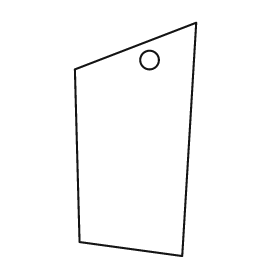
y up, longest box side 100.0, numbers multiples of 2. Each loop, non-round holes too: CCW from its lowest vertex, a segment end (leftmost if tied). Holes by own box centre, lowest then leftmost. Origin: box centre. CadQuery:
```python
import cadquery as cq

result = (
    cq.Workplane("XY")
    .moveTo(20.0, -50.0)
    .lineTo(26.0, 50.0)
    .lineTo(-26.0, 30.0)
    .lineTo(-24.0, -44.0)
    .close()
    .moveTo(6.0, 34.0)
    .circle(4.0)
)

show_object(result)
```